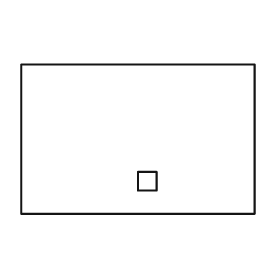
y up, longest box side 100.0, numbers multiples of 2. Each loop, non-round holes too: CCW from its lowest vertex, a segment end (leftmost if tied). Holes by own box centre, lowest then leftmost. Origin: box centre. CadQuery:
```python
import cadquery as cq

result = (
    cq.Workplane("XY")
    .moveTo(-50.0, -32.0)
    .lineTo(50.0, -32.0)
    .lineTo(50.0, 32.0)
    .lineTo(-50.0, 32.0)
    .close()
    .moveTo(0.0, -22.0)
    .lineTo(8.0, -22.0)
    .lineTo(8.0, -14.0)
    .lineTo(0.0, -14.0)
    .close()
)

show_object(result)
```